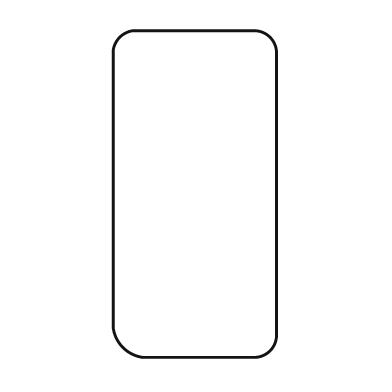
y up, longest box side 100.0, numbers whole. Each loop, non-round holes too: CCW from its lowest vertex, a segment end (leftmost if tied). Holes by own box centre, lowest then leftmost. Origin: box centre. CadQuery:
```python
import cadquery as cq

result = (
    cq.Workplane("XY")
    .moveTo(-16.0, -50.0)
    .lineTo(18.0, -50.0)
    .threePointArc((23.0, -48.0), (25.0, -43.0))
    .lineTo(25.0, 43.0)
    .threePointArc((23.0, 48.0), (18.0, 50.0))
    .lineTo(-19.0, 50.0)
    .threePointArc((-23.0, 48.0), (-25.0, 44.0))
    .lineTo(-25.0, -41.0)
    .threePointArc((-22.0, -47.0), (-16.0, -50.0))
    .close()
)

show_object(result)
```